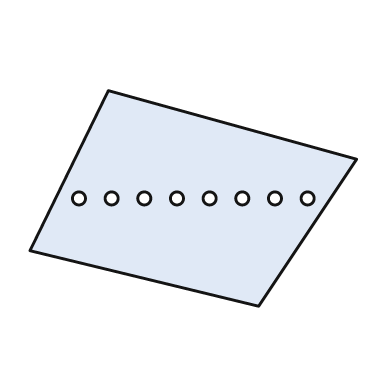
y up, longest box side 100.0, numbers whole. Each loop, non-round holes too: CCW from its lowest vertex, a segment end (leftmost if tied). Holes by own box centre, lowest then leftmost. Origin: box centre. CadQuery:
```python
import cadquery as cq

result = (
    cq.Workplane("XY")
    .moveTo(20.0, -33.0)
    .lineTo(50.0, 12.0)
    .lineTo(-26.0, 33.0)
    .lineTo(-50.0, -16.0)
    .close()
    .moveTo(-35.0, 0.0)
    .circle(2.0)
    .moveTo(-25.0, 0.0)
    .circle(2.0)
    .moveTo(-15.0, 0.0)
    .circle(2.0)
    .moveTo(-5.0, 0.0)
    .circle(2.0)
    .moveTo(5.0, 0.0)
    .circle(2.0)
    .moveTo(15.0, 0.0)
    .circle(2.0)
    .moveTo(25.0, 0.0)
    .circle(2.0)
    .moveTo(35.0, 0.0)
    .circle(2.0)
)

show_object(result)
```